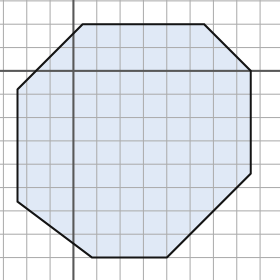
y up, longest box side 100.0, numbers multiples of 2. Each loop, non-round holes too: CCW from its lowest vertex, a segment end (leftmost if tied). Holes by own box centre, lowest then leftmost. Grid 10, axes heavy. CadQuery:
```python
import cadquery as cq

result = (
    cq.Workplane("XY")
    .moveTo(8.0, -80.0)
    .lineTo(40.0, -80.0)
    .lineTo(76.0, -44.0)
    .lineTo(76.0, 0.0)
    .lineTo(56.0, 20.0)
    .lineTo(4.0, 20.0)
    .lineTo(-24.0, -8.0)
    .lineTo(-24.0, -56.0)
    .close()
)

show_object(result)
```